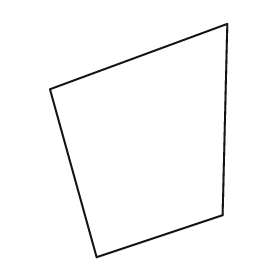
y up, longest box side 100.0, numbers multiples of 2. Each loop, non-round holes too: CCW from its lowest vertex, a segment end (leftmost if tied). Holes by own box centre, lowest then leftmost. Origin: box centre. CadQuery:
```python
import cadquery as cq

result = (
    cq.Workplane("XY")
    .moveTo(-18.0, -50.0)
    .lineTo(36.0, -32.0)
    .lineTo(38.0, 50.0)
    .lineTo(-38.0, 22.0)
    .close()
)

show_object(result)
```